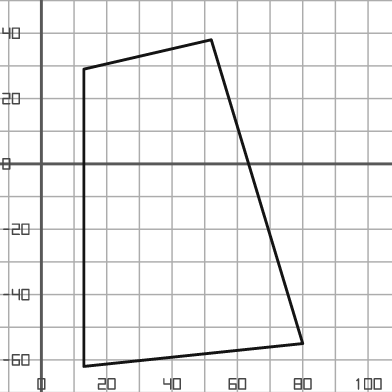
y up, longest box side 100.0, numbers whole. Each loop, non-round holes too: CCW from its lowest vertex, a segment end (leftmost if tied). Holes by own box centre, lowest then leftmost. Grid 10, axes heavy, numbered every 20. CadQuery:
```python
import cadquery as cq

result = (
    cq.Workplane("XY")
    .moveTo(13.0, -62.0)
    .lineTo(80.0, -55.0)
    .lineTo(52.0, 38.0)
    .lineTo(13.0, 29.0)
    .close()
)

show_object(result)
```